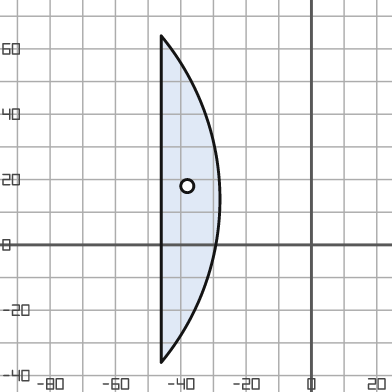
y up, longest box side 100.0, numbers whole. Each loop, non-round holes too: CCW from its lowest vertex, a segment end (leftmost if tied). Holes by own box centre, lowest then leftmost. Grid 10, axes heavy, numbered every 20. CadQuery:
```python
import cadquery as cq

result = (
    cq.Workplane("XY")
    .moveTo(-46.0, -36.0)
    .threePointArc((-28.0, 14.0), (-46.0, 64.0))
    .close()
    .moveTo(-38.0, 18.0)
    .circle(2.0)
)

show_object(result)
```